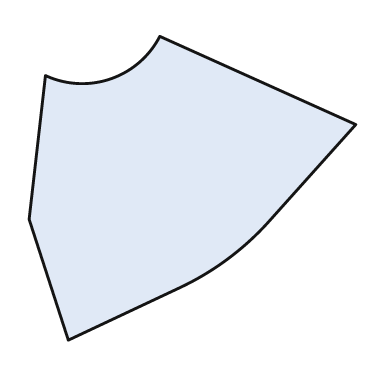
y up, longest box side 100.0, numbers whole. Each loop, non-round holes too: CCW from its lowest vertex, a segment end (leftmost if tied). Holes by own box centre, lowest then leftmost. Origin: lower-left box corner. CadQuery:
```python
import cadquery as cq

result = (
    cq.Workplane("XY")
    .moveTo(12.0, 0.0)
    .lineTo(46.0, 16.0)
    .threePointArc((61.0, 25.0), (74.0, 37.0))
    .lineTo(100.0, 66.0)
    .lineTo(40.0, 93.0)
    .threePointArc((25.0, 80.0), (5.0, 81.0))
    .lineTo(0.0, 37.0)
    .close()
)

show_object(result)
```